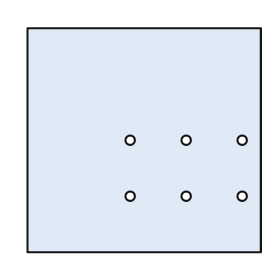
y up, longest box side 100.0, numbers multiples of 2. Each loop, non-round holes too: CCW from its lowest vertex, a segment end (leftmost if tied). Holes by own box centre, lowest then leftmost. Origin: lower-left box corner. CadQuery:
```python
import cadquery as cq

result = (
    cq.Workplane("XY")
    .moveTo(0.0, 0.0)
    .lineTo(100.0, 0.0)
    .lineTo(100.0, 96.0)
    .lineTo(0.0, 96.0)
    .close()
    .moveTo(44.0, 24.0)
    .circle(2.0)
    .moveTo(68.0, 24.0)
    .circle(2.0)
    .moveTo(92.0, 24.0)
    .circle(2.0)
    .moveTo(44.0, 48.0)
    .circle(2.0)
    .moveTo(68.0, 48.0)
    .circle(2.0)
    .moveTo(92.0, 48.0)
    .circle(2.0)
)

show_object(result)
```